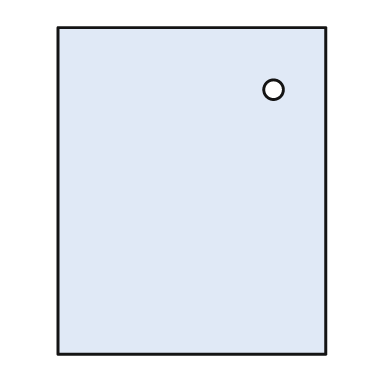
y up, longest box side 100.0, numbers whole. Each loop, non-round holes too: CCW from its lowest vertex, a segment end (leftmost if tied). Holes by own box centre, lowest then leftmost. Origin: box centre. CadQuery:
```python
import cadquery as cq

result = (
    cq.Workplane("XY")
    .moveTo(-41.0, -50.0)
    .lineTo(41.0, -50.0)
    .lineTo(41.0, 50.0)
    .lineTo(-41.0, 50.0)
    .close()
    .moveTo(25.0, 31.0)
    .circle(3.0)
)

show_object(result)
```